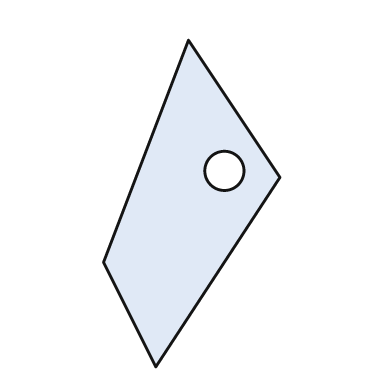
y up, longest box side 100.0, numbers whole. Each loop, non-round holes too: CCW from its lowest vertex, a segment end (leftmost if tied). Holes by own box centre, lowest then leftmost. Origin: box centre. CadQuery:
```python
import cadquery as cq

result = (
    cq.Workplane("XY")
    .moveTo(-11.0, -50.0)
    .lineTo(27.0, 8.0)
    .lineTo(-1.0, 50.0)
    .lineTo(-27.0, -18.0)
    .close()
    .moveTo(10.0, 10.0)
    .circle(6.0)
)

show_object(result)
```